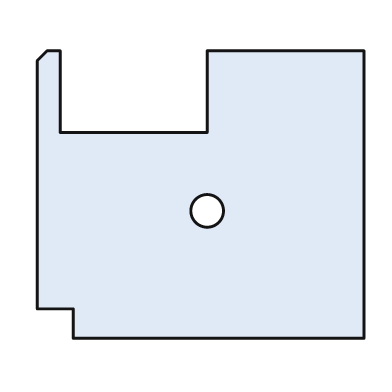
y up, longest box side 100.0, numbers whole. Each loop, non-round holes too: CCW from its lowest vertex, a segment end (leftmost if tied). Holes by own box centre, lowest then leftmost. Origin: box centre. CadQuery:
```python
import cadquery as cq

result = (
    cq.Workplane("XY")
    .moveTo(-39.0, -44.0)
    .lineTo(50.0, -44.0)
    .lineTo(50.0, 44.0)
    .lineTo(2.0, 44.0)
    .lineTo(2.0, 19.0)
    .lineTo(-43.0, 19.0)
    .lineTo(-43.0, 44.0)
    .lineTo(-47.0, 44.0)
    .lineTo(-50.0, 41.0)
    .lineTo(-50.0, -35.0)
    .lineTo(-39.0, -35.0)
    .close()
    .moveTo(2.0, -5.0)
    .circle(5.0)
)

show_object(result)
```